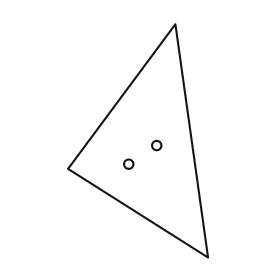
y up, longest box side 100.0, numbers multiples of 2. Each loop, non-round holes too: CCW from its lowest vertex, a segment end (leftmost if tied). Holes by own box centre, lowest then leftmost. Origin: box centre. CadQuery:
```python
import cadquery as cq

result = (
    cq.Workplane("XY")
    .moveTo(30.0, -50.0)
    .lineTo(16.0, 50.0)
    .lineTo(-30.0, -12.0)
    .close()
    .moveTo(-4.0, -10.0)
    .circle(2.0)
    .moveTo(8.0, -2.0)
    .circle(2.0)
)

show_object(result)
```